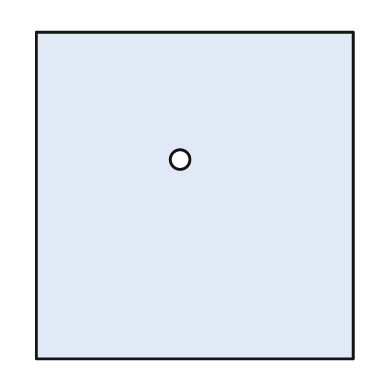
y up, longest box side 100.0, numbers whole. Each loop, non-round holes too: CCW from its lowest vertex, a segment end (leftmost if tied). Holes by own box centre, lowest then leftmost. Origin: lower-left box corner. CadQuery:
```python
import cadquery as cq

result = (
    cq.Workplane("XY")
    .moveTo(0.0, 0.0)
    .lineTo(97.0, 0.0)
    .lineTo(97.0, 100.0)
    .lineTo(0.0, 100.0)
    .close()
    .moveTo(44.0, 61.0)
    .circle(3.0)
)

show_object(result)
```